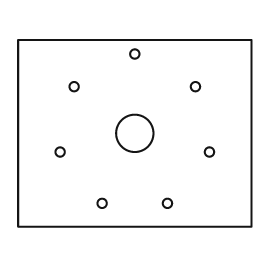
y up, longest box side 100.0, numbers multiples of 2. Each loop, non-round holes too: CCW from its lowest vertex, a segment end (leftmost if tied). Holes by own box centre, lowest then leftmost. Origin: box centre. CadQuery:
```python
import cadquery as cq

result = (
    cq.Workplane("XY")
    .moveTo(-50.0, -40.0)
    .lineTo(50.0, -40.0)
    .lineTo(50.0, 40.0)
    .lineTo(-50.0, 40.0)
    .close()
    .moveTo(-14.0, -30.0)
    .circle(2.0)
    .moveTo(14.0, -30.0)
    .circle(2.0)
    .moveTo(-32.0, -8.0)
    .circle(2.0)
    .moveTo(32.0, -8.0)
    .circle(2.0)
    .moveTo(0.0, 0.0)
    .circle(8.0)
    .moveTo(-26.0, 20.0)
    .circle(2.0)
    .moveTo(26.0, 20.0)
    .circle(2.0)
    .moveTo(0.0, 34.0)
    .circle(2.0)
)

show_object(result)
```